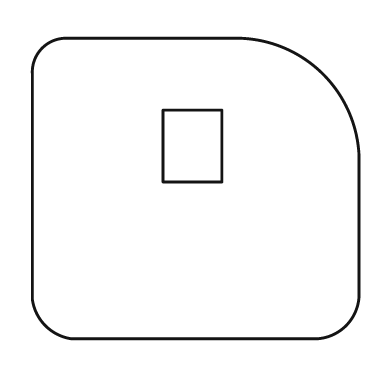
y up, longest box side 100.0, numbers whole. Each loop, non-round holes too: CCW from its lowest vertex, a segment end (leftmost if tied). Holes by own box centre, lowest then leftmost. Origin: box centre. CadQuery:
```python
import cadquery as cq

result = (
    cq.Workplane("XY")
    .moveTo(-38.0, -46.0)
    .lineTo(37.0, -46.0)
    .threePointArc((46.0, -42.0), (50.0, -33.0))
    .lineTo(50.0, 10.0)
    .threePointArc((39.0, 35.0), (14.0, 46.0))
    .lineTo(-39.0, 46.0)
    .threePointArc((-47.0, 43.0), (-50.0, 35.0))
    .lineTo(-50.0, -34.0)
    .threePointArc((-46.0, -42.0), (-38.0, -46.0))
    .close()
    .moveTo(-10.0, 2.0)
    .lineTo(8.0, 2.0)
    .lineTo(8.0, 24.0)
    .lineTo(-10.0, 24.0)
    .close()
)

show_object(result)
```